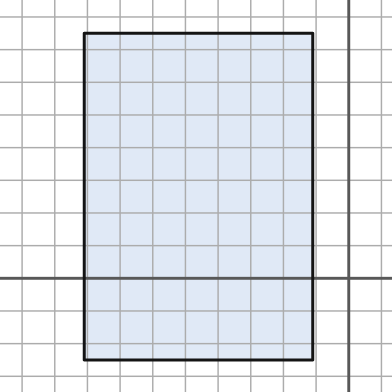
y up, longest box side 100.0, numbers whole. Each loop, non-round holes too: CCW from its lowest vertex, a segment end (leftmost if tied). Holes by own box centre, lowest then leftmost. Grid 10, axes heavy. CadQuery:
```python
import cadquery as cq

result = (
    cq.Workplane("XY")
    .moveTo(-81.0, -25.0)
    .lineTo(-11.0, -25.0)
    .lineTo(-11.0, 75.0)
    .lineTo(-81.0, 75.0)
    .close()
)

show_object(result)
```